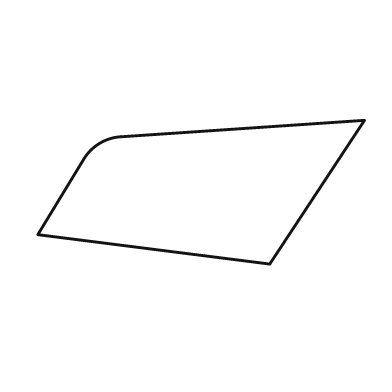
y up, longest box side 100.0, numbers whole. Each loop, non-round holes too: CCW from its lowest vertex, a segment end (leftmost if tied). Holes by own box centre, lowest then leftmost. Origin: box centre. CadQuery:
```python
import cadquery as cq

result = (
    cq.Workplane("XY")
    .moveTo(21.0, -22.0)
    .lineTo(50.0, 22.0)
    .lineTo(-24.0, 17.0)
    .threePointArc((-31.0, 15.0), (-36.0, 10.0))
    .lineTo(-50.0, -13.0)
    .close()
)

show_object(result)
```